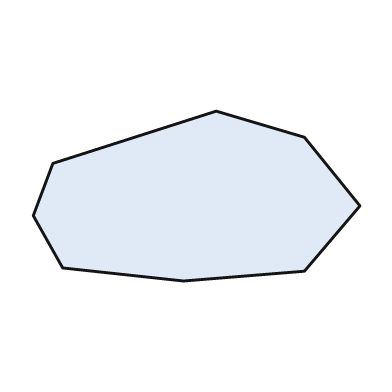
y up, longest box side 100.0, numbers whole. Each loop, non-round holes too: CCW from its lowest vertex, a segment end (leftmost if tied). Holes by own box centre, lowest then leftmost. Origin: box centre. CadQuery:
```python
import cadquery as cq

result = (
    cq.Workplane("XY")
    .moveTo(-4.0, -26.0)
    .lineTo(33.0, -23.0)
    .lineTo(50.0, -3.0)
    .lineTo(33.0, 18.0)
    .lineTo(6.0, 26.0)
    .lineTo(-44.0, 10.0)
    .lineTo(-50.0, -6.0)
    .lineTo(-41.0, -22.0)
    .close()
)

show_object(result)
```